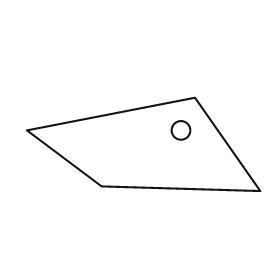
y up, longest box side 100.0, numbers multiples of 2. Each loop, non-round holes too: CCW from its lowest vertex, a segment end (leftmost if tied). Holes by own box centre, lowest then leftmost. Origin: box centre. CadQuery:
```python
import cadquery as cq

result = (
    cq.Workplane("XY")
    .moveTo(50.0, -20.0)
    .lineTo(22.0, 20.0)
    .lineTo(-50.0, 6.0)
    .lineTo(-18.0, -18.0)
    .close()
    .moveTo(16.0, 6.0)
    .circle(4.0)
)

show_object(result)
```